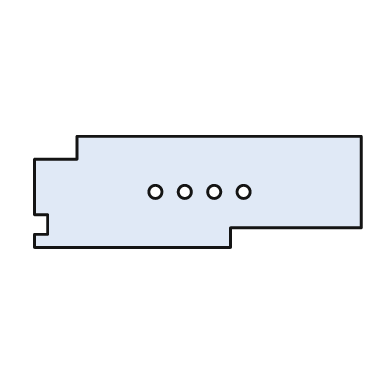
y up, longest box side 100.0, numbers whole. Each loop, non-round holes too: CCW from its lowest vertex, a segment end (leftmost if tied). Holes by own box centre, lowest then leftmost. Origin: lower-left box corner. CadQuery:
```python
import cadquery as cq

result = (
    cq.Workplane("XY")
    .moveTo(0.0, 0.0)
    .lineTo(60.0, 0.0)
    .lineTo(60.0, 6.0)
    .lineTo(100.0, 6.0)
    .lineTo(100.0, 34.0)
    .lineTo(13.0, 34.0)
    .lineTo(13.0, 27.0)
    .lineTo(0.0, 27.0)
    .lineTo(0.0, 10.0)
    .lineTo(4.0, 10.0)
    .lineTo(4.0, 4.0)
    .lineTo(0.0, 4.0)
    .close()
    .moveTo(37.0, 17.0)
    .circle(2.0)
    .moveTo(46.0, 17.0)
    .circle(2.0)
    .moveTo(55.0, 17.0)
    .circle(2.0)
    .moveTo(64.0, 17.0)
    .circle(2.0)
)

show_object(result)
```